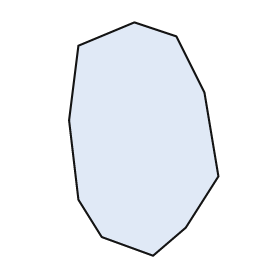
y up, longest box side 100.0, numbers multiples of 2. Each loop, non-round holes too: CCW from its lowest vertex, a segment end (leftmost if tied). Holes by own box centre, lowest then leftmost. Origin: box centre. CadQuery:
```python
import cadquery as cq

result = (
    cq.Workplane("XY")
    .moveTo(4.0, -50.0)
    .lineTo(18.0, -38.0)
    .lineTo(32.0, -16.0)
    .lineTo(26.0, 20.0)
    .lineTo(14.0, 44.0)
    .lineTo(-4.0, 50.0)
    .lineTo(-28.0, 40.0)
    .lineTo(-32.0, 8.0)
    .lineTo(-28.0, -26.0)
    .lineTo(-18.0, -42.0)
    .close()
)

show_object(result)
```